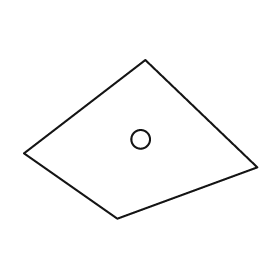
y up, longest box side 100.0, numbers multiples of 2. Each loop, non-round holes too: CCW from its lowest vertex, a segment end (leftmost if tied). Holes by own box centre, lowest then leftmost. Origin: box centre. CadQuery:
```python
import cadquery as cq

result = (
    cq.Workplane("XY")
    .moveTo(-10.0, -34.0)
    .lineTo(50.0, -12.0)
    .lineTo(2.0, 34.0)
    .lineTo(-50.0, -6.0)
    .close()
    .moveTo(0.0, 0.0)
    .circle(4.0)
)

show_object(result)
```